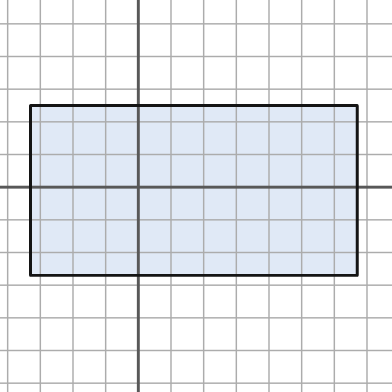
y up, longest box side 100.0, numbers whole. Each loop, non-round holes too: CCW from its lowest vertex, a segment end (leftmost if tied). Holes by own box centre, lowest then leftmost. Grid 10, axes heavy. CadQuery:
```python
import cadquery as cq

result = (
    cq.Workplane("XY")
    .moveTo(-33.0, -27.0)
    .lineTo(67.0, -27.0)
    .lineTo(67.0, 25.0)
    .lineTo(-33.0, 25.0)
    .close()
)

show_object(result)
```